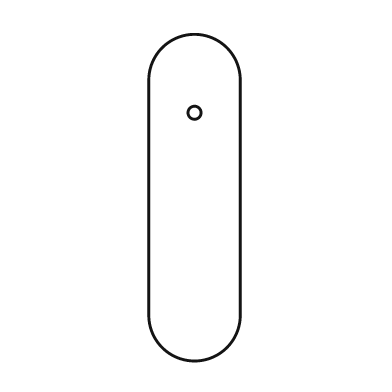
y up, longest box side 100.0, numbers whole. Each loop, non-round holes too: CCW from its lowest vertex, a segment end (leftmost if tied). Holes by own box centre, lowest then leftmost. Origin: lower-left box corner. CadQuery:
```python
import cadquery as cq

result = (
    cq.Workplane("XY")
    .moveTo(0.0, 14.0)
    .threePointArc((14.0, 0.0), (28.0, 14.0))
    .lineTo(28.0, 86.0)
    .threePointArc((14.0, 100.0), (0.0, 86.0))
    .close()
    .moveTo(14.0, 76.0)
    .circle(2.0)
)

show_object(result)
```